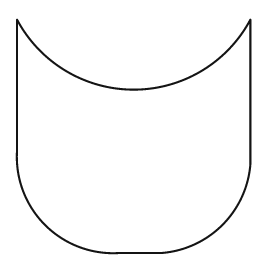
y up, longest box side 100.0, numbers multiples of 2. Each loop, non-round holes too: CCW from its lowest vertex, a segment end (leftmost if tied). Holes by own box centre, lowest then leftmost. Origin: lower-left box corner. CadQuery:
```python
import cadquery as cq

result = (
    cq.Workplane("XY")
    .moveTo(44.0, 0.0)
    .lineTo(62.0, 0.0)
    .threePointArc((88.0, 12.0), (100.0, 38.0))
    .lineTo(100.0, 100.0)
    .threePointArc((50.0, 70.0), (0.0, 100.0))
    .lineTo(0.0, 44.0)
    .threePointArc((12.0, 12.0), (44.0, 0.0))
    .close()
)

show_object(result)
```